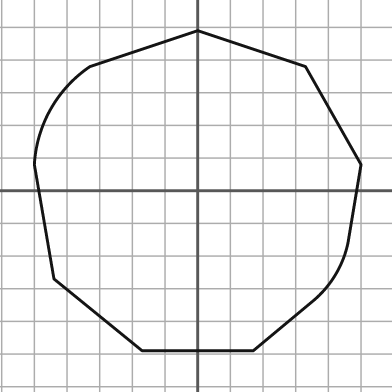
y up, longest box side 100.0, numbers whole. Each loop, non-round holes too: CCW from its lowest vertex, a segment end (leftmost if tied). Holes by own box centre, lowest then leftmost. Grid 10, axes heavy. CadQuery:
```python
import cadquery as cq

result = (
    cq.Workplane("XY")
    .moveTo(-17.0, -49.0)
    .lineTo(17.0, -49.0)
    .lineTo(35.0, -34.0)
    .threePointArc((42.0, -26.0), (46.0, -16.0))
    .lineTo(50.0, 8.0)
    .lineTo(33.0, 38.0)
    .lineTo(0.0, 49.0)
    .lineTo(-33.0, 38.0)
    .threePointArc((-45.0, 25.0), (-50.0, 8.0))
    .lineTo(-44.0, -27.0)
    .close()
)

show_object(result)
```